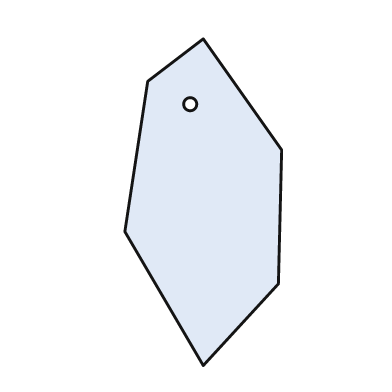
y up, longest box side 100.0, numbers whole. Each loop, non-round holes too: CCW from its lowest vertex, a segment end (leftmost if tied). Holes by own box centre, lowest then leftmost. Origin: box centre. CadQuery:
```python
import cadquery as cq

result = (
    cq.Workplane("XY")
    .moveTo(0.0, -50.0)
    .lineTo(23.0, -25.0)
    .lineTo(24.0, 16.0)
    .lineTo(0.0, 50.0)
    .lineTo(-17.0, 37.0)
    .lineTo(-24.0, -9.0)
    .close()
    .moveTo(-4.0, 30.0)
    .circle(2.0)
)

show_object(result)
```